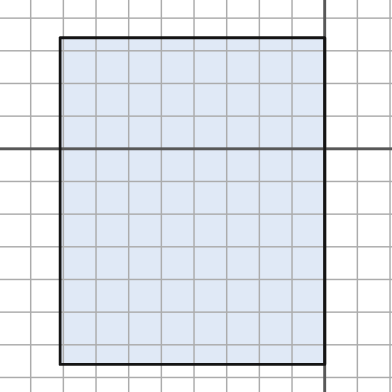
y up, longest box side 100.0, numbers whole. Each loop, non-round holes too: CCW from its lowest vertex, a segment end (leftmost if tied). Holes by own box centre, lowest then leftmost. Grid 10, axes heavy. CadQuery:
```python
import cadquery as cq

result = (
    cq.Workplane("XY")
    .moveTo(-81.0, -66.0)
    .lineTo(0.0, -66.0)
    .lineTo(0.0, 34.0)
    .lineTo(-81.0, 34.0)
    .close()
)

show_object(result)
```